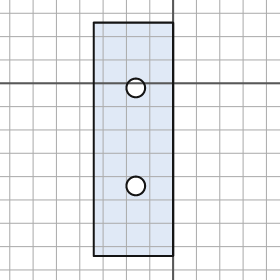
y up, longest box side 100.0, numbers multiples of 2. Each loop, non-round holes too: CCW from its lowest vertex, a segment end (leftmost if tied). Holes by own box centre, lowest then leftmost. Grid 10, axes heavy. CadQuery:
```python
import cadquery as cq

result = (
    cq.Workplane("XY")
    .moveTo(-34.0, -74.0)
    .lineTo(0.0, -74.0)
    .lineTo(0.0, 26.0)
    .lineTo(-34.0, 26.0)
    .close()
    .moveTo(-16.0, -44.0)
    .circle(4.0)
    .moveTo(-16.0, -2.0)
    .circle(4.0)
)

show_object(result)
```